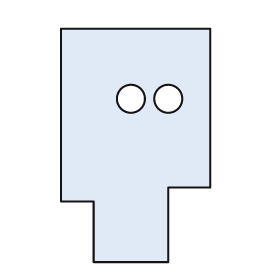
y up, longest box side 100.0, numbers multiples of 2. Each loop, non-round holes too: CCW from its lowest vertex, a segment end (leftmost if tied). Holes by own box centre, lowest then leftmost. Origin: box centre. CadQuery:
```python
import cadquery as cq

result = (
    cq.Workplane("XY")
    .moveTo(-18.0, -50.0)
    .lineTo(14.0, -50.0)
    .lineTo(14.0, -18.0)
    .lineTo(32.0, -18.0)
    .lineTo(32.0, 50.0)
    .lineTo(-32.0, 50.0)
    .lineTo(-32.0, -24.0)
    .lineTo(-18.0, -24.0)
    .close()
    .moveTo(-2.0, 20.0)
    .circle(6.0)
    .moveTo(14.0, 20.0)
    .circle(6.0)
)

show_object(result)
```